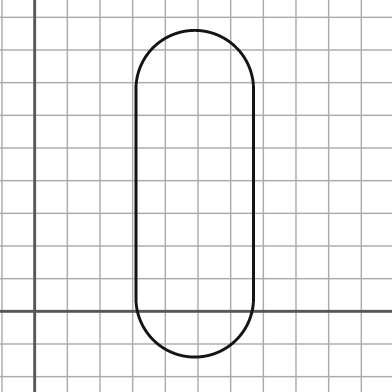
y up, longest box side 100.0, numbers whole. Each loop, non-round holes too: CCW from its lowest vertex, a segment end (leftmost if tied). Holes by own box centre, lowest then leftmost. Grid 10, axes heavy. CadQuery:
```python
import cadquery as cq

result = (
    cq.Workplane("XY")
    .moveTo(31.0, 4.0)
    .threePointArc((49.0, -14.0), (67.0, 4.0))
    .lineTo(67.0, 68.0)
    .threePointArc((49.0, 86.0), (31.0, 68.0))
    .close()
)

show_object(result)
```